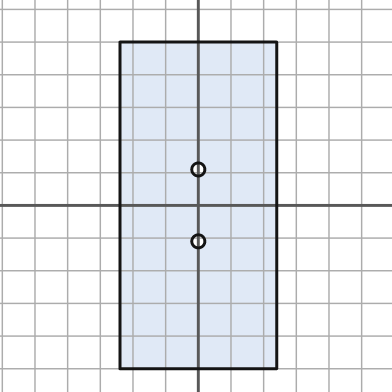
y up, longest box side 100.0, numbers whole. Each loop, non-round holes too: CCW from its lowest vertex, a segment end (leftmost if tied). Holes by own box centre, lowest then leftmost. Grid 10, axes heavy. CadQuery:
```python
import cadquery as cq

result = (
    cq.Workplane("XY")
    .moveTo(-24.0, -50.0)
    .lineTo(24.0, -50.0)
    .lineTo(24.0, 50.0)
    .lineTo(-24.0, 50.0)
    .close()
    .moveTo(0.0, -11.0)
    .circle(2.0)
    .moveTo(0.0, 11.0)
    .circle(2.0)
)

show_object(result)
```